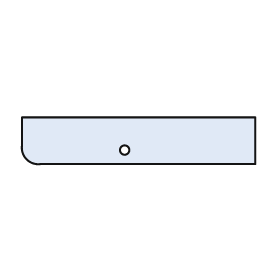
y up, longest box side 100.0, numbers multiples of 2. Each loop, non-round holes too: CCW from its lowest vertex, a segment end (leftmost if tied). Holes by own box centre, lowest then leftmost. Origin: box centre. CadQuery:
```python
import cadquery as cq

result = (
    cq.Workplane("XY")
    .moveTo(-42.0, -10.0)
    .lineTo(50.0, -10.0)
    .lineTo(50.0, 10.0)
    .lineTo(-50.0, 10.0)
    .lineTo(-50.0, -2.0)
    .threePointArc((-48.0, -8.0), (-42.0, -10.0))
    .close()
    .moveTo(-6.0, -4.0)
    .circle(2.0)
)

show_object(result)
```